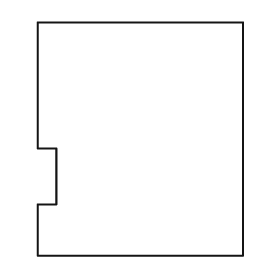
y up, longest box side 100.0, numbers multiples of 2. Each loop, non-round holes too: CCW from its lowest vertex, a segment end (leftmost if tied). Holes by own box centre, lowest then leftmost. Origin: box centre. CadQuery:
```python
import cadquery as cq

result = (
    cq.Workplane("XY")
    .moveTo(-44.0, -50.0)
    .lineTo(44.0, -50.0)
    .lineTo(44.0, 50.0)
    .lineTo(-44.0, 50.0)
    .lineTo(-44.0, -4.0)
    .lineTo(-36.0, -4.0)
    .lineTo(-36.0, -28.0)
    .lineTo(-44.0, -28.0)
    .close()
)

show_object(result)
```